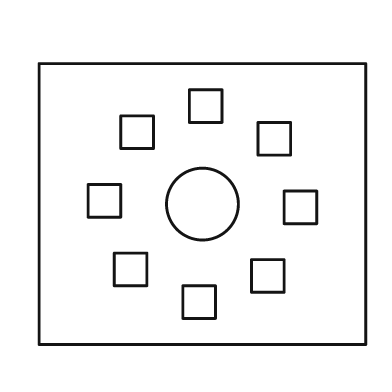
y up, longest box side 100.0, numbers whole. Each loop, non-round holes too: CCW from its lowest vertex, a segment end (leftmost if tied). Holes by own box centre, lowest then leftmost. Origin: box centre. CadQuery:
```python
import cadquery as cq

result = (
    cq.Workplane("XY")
    .moveTo(-50.0, -43.0)
    .lineTo(50.0, -43.0)
    .lineTo(50.0, 43.0)
    .lineTo(-50.0, 43.0)
    .close()
    .moveTo(-6.0, -35.0)
    .lineTo(4.0, -35.0)
    .lineTo(4.0, -25.0)
    .lineTo(-6.0, -25.0)
    .close()
    .moveTo(15.0, -27.0)
    .lineTo(25.0, -27.0)
    .lineTo(25.0, -17.0)
    .lineTo(15.0, -17.0)
    .close()
    .moveTo(-27.0, -25.0)
    .lineTo(-17.0, -25.0)
    .lineTo(-17.0, -15.0)
    .lineTo(-27.0, -15.0)
    .close()
    .moveTo(25.0, -6.0)
    .lineTo(35.0, -6.0)
    .lineTo(35.0, 4.0)
    .lineTo(25.0, 4.0)
    .close()
    .moveTo(0.0, 0.0)
    .circle(11.0)
    .moveTo(-35.0, -4.0)
    .lineTo(-25.0, -4.0)
    .lineTo(-25.0, 6.0)
    .lineTo(-35.0, 6.0)
    .close()
    .moveTo(17.0, 15.0)
    .lineTo(27.0, 15.0)
    .lineTo(27.0, 25.0)
    .lineTo(17.0, 25.0)
    .close()
    .moveTo(-25.0, 17.0)
    .lineTo(-15.0, 17.0)
    .lineTo(-15.0, 27.0)
    .lineTo(-25.0, 27.0)
    .close()
    .moveTo(-4.0, 25.0)
    .lineTo(6.0, 25.0)
    .lineTo(6.0, 35.0)
    .lineTo(-4.0, 35.0)
    .close()
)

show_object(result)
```